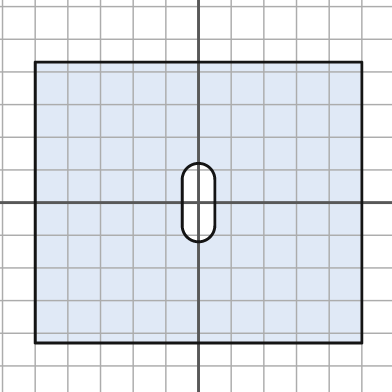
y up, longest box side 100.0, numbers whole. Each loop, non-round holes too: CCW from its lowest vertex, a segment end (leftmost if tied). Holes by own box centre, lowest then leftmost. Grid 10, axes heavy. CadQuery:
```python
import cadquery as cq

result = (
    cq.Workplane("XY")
    .moveTo(-50.0, -43.0)
    .lineTo(50.0, -43.0)
    .lineTo(50.0, 43.0)
    .lineTo(-50.0, 43.0)
    .close()
    .moveTo(-5.0, -7.0)
    .threePointArc((0.0, -12.0), (5.0, -7.0))
    .lineTo(5.0, 7.0)
    .threePointArc((0.0, 12.0), (-5.0, 7.0))
    .close()
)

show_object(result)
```